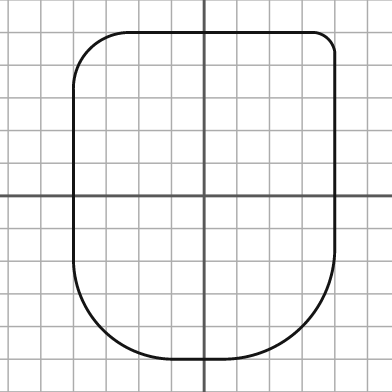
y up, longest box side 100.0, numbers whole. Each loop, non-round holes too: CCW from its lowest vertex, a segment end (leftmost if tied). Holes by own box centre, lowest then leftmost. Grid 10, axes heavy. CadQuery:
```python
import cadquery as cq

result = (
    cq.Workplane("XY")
    .moveTo(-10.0, -50.0)
    .lineTo(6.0, -50.0)
    .threePointArc((30.0, -40.0), (40.0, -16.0))
    .lineTo(40.0, 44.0)
    .threePointArc((38.0, 48.0), (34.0, 50.0))
    .lineTo(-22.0, 50.0)
    .threePointArc((-35.0, 45.0), (-40.0, 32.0))
    .lineTo(-40.0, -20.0)
    .threePointArc((-31.0, -41.0), (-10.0, -50.0))
    .close()
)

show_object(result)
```